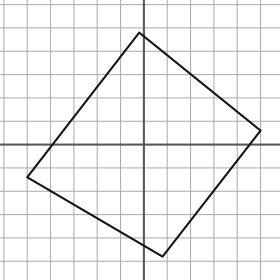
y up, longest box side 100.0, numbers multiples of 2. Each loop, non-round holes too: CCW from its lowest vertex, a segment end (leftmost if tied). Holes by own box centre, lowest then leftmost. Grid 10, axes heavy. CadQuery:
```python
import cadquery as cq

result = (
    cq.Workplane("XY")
    .moveTo(8.0, -48.0)
    .lineTo(50.0, 6.0)
    .lineTo(-2.0, 48.0)
    .lineTo(-50.0, -14.0)
    .close()
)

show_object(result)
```